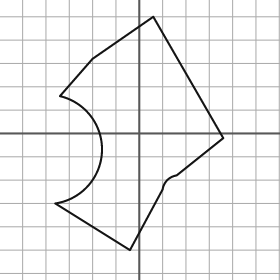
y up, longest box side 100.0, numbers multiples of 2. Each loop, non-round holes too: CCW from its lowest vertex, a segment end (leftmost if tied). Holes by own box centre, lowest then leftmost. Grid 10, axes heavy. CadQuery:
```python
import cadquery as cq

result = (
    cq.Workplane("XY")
    .moveTo(-4.0, -50.0)
    .lineTo(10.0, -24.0)
    .threePointArc((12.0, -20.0), (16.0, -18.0))
    .lineTo(36.0, -2.0)
    .lineTo(6.0, 50.0)
    .lineTo(-20.0, 32.0)
    .lineTo(-34.0, 16.0)
    .threePointArc((-16.0, -8.0), (-36.0, -30.0))
    .close()
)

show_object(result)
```